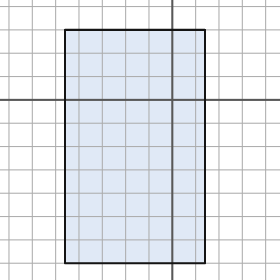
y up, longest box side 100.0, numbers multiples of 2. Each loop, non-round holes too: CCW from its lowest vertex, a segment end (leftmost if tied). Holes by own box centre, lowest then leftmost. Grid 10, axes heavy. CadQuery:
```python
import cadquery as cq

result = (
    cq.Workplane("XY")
    .moveTo(-46.0, -70.0)
    .lineTo(14.0, -70.0)
    .lineTo(14.0, 30.0)
    .lineTo(-46.0, 30.0)
    .close()
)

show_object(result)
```